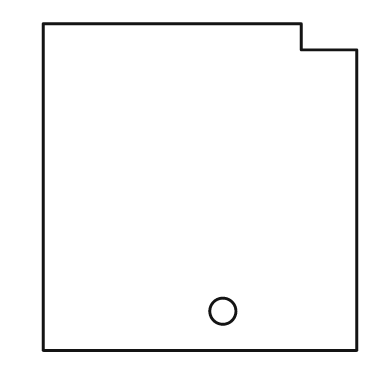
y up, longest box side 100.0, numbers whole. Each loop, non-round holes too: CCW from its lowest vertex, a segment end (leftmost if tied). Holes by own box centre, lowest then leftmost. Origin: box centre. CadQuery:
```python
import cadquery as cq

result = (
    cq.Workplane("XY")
    .moveTo(-48.0, -50.0)
    .lineTo(48.0, -50.0)
    .lineTo(48.0, 42.0)
    .lineTo(31.0, 42.0)
    .lineTo(31.0, 50.0)
    .lineTo(-48.0, 50.0)
    .close()
    .moveTo(7.0, -38.0)
    .circle(4.0)
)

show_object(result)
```